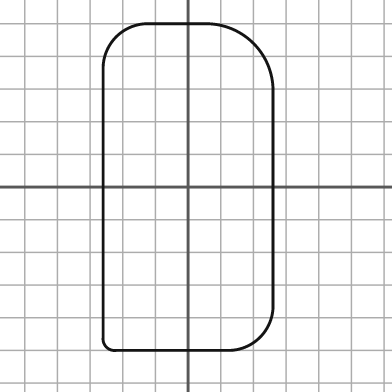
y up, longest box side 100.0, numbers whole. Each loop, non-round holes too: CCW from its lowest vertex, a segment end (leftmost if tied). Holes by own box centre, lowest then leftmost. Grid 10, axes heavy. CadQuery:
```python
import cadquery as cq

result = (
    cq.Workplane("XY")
    .moveTo(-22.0, -50.0)
    .lineTo(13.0, -50.0)
    .threePointArc((22.0, -46.0), (26.0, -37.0))
    .lineTo(26.0, 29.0)
    .threePointArc((20.0, 44.0), (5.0, 50.0))
    .lineTo(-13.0, 50.0)
    .threePointArc((-22.0, 46.0), (-26.0, 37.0))
    .lineTo(-26.0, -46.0)
    .threePointArc((-25.0, -49.0), (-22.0, -50.0))
    .close()
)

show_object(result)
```